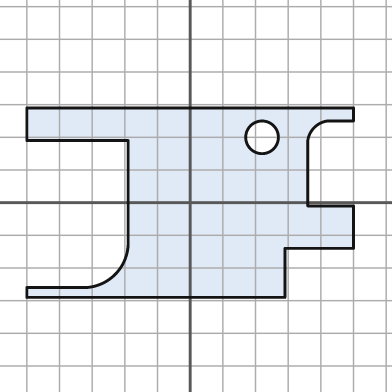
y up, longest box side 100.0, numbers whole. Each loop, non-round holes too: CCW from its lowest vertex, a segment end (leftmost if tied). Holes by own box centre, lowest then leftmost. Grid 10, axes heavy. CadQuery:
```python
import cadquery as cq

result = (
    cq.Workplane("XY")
    .moveTo(-50.0, -29.0)
    .lineTo(29.0, -29.0)
    .lineTo(29.0, -14.0)
    .lineTo(50.0, -14.0)
    .lineTo(50.0, -1.0)
    .lineTo(36.0, -1.0)
    .lineTo(36.0, 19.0)
    .threePointArc((38.0, 23.0), (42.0, 25.0))
    .lineTo(50.0, 25.0)
    .lineTo(50.0, 29.0)
    .lineTo(-50.0, 29.0)
    .lineTo(-50.0, 19.0)
    .lineTo(-19.0, 19.0)
    .lineTo(-19.0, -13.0)
    .threePointArc((-23.0, -22.0), (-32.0, -26.0))
    .lineTo(-50.0, -26.0)
    .close()
    .moveTo(22.0, 20.0)
    .circle(5.0)
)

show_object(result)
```